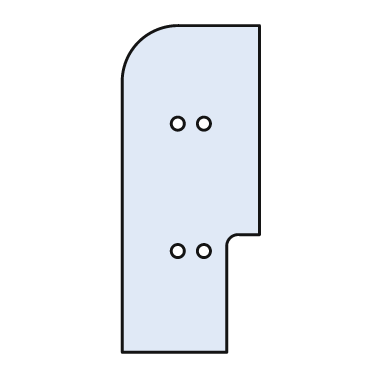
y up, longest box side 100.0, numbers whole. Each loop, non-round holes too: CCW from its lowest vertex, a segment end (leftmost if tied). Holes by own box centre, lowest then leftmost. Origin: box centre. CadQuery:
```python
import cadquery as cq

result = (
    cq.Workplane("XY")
    .moveTo(-21.0, -50.0)
    .lineTo(11.0, -50.0)
    .lineTo(11.0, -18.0)
    .threePointArc((12.0, -15.0), (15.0, -14.0))
    .lineTo(21.0, -14.0)
    .lineTo(21.0, 50.0)
    .lineTo(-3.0, 50.0)
    .threePointArc((-16.0, 45.0), (-21.0, 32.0))
    .close()
    .moveTo(-4.0, -19.0)
    .circle(2.0)
    .moveTo(4.0, -19.0)
    .circle(2.0)
    .moveTo(-4.0, 20.0)
    .circle(2.0)
    .moveTo(4.0, 20.0)
    .circle(2.0)
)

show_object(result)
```